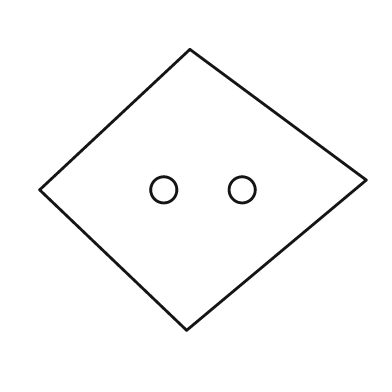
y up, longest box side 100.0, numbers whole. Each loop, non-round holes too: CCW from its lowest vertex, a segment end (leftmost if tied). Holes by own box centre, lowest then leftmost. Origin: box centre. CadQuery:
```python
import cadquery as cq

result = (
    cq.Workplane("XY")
    .moveTo(-5.0, -43.0)
    .lineTo(50.0, 3.0)
    .lineTo(-4.0, 43.0)
    .lineTo(-50.0, 0.0)
    .close()
    .moveTo(-12.0, 0.0)
    .circle(4.0)
    .moveTo(12.0, 0.0)
    .circle(4.0)
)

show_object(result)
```